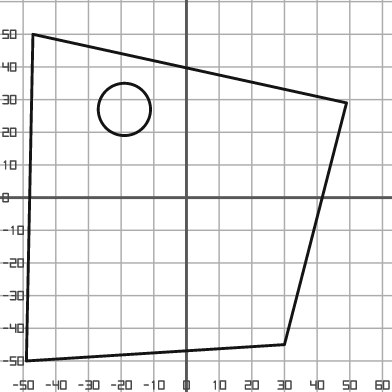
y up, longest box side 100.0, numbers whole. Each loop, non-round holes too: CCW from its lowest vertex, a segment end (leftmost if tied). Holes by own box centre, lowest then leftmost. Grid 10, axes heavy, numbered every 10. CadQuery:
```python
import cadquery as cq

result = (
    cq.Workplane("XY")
    .moveTo(-49.0, -50.0)
    .lineTo(30.0, -45.0)
    .lineTo(49.0, 29.0)
    .lineTo(-47.0, 50.0)
    .close()
    .moveTo(-19.0, 27.0)
    .circle(8.0)
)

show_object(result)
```